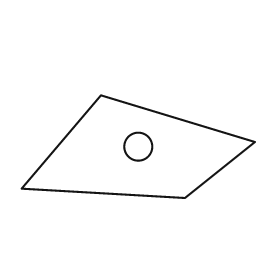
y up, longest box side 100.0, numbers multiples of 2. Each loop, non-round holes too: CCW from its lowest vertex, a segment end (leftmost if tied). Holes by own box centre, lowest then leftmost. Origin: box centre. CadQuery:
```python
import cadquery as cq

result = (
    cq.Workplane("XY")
    .moveTo(20.0, -22.0)
    .lineTo(50.0, 2.0)
    .lineTo(-16.0, 22.0)
    .lineTo(-50.0, -18.0)
    .close()
    .moveTo(0.0, 0.0)
    .circle(6.0)
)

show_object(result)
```